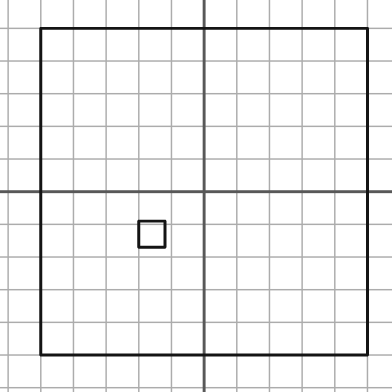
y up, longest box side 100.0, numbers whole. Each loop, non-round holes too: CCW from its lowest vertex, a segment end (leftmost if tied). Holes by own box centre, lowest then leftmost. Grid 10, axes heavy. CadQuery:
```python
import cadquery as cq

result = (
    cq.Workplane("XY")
    .moveTo(-50.0, -50.0)
    .lineTo(50.0, -50.0)
    .lineTo(50.0, 50.0)
    .lineTo(-50.0, 50.0)
    .close()
    .moveTo(-20.0, -17.0)
    .lineTo(-12.0, -17.0)
    .lineTo(-12.0, -9.0)
    .lineTo(-20.0, -9.0)
    .close()
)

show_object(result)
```